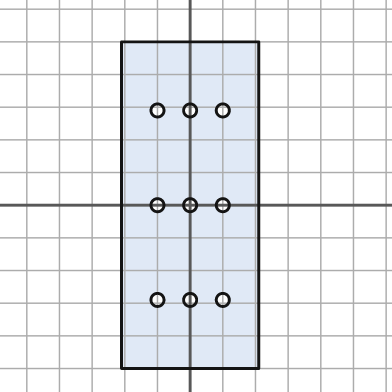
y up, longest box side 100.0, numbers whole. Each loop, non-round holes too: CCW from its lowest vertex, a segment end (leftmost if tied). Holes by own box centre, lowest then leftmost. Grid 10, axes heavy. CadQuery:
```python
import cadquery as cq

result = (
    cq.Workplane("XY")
    .moveTo(-21.0, -50.0)
    .lineTo(21.0, -50.0)
    .lineTo(21.0, 50.0)
    .lineTo(-21.0, 50.0)
    .close()
    .moveTo(-10.0, -29.0)
    .circle(2.0)
    .moveTo(0.0, -29.0)
    .circle(2.0)
    .moveTo(10.0, -29.0)
    .circle(2.0)
    .moveTo(-10.0, 0.0)
    .circle(2.0)
    .moveTo(0.0, 0.0)
    .circle(2.0)
    .moveTo(10.0, 0.0)
    .circle(2.0)
    .moveTo(-10.0, 29.0)
    .circle(2.0)
    .moveTo(0.0, 29.0)
    .circle(2.0)
    .moveTo(10.0, 29.0)
    .circle(2.0)
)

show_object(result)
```